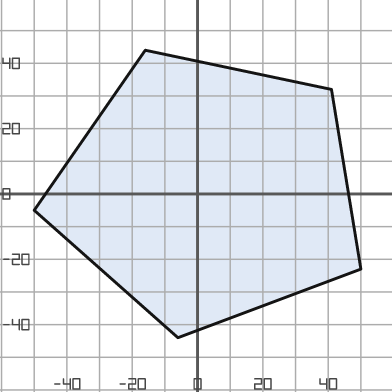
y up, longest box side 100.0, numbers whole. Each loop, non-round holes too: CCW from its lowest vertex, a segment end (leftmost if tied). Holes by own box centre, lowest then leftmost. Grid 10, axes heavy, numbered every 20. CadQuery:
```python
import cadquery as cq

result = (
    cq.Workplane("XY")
    .moveTo(-6.0, -44.0)
    .lineTo(50.0, -23.0)
    .lineTo(41.0, 32.0)
    .lineTo(-16.0, 44.0)
    .lineTo(-50.0, -5.0)
    .close()
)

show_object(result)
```